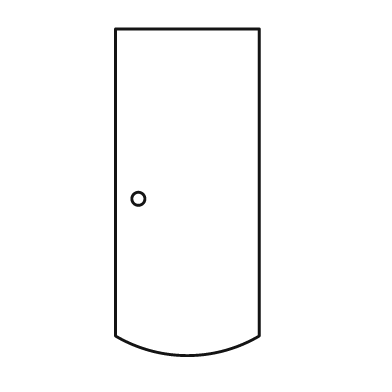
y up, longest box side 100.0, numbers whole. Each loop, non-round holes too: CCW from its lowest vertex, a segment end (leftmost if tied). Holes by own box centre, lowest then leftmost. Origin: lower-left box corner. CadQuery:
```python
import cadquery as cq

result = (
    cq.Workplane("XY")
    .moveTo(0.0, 6.0)
    .threePointArc((22.0, 0.0), (44.0, 6.0))
    .lineTo(44.0, 100.0)
    .lineTo(0.0, 100.0)
    .close()
    .moveTo(7.0, 48.0)
    .circle(2.0)
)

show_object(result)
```